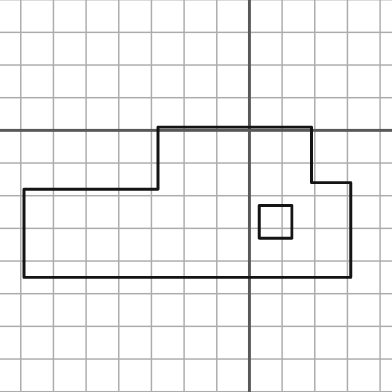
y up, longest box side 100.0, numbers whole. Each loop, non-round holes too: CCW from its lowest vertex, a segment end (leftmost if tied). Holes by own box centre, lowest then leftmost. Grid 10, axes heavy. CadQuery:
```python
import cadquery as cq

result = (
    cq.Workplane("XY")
    .moveTo(-69.0, -45.0)
    .lineTo(31.0, -45.0)
    .lineTo(31.0, -16.0)
    .lineTo(19.0, -16.0)
    .lineTo(19.0, 1.0)
    .lineTo(-28.0, 1.0)
    .lineTo(-28.0, -18.0)
    .lineTo(-69.0, -18.0)
    .close()
    .moveTo(3.0, -33.0)
    .lineTo(13.0, -33.0)
    .lineTo(13.0, -23.0)
    .lineTo(3.0, -23.0)
    .close()
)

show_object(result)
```